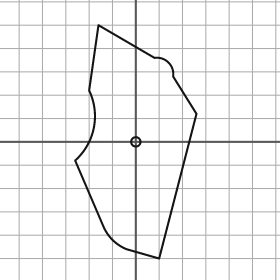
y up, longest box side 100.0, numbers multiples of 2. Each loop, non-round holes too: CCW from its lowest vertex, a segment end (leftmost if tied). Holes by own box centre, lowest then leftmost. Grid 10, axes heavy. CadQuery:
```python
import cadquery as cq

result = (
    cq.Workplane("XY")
    .moveTo(10.0, -50.0)
    .lineTo(26.0, 12.0)
    .lineTo(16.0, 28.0)
    .threePointArc((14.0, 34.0), (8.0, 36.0))
    .lineTo(-16.0, 50.0)
    .lineTo(-20.0, 22.0)
    .threePointArc((-18.0, 6.0), (-26.0, -8.0))
    .lineTo(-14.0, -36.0)
    .threePointArc((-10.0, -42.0), (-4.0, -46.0))
    .close()
    .moveTo(0.0, 0.0)
    .circle(2.0)
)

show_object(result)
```